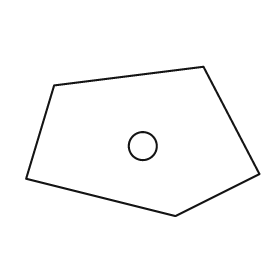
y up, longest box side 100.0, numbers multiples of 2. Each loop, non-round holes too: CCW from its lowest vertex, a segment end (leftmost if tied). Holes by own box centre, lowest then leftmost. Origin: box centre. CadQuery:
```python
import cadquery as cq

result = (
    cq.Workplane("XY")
    .moveTo(14.0, -32.0)
    .lineTo(50.0, -14.0)
    .lineTo(26.0, 32.0)
    .lineTo(-38.0, 24.0)
    .lineTo(-50.0, -16.0)
    .close()
    .moveTo(0.0, -2.0)
    .circle(6.0)
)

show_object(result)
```